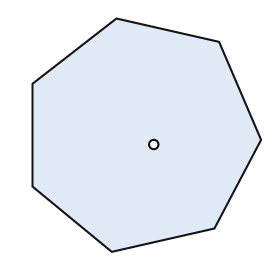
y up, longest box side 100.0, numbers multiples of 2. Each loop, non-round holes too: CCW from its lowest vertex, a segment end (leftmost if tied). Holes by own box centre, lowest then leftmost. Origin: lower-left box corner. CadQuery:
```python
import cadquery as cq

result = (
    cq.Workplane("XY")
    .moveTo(34.0, 0.0)
    .lineTo(78.0, 10.0)
    .lineTo(98.0, 48.0)
    .lineTo(80.0, 90.0)
    .lineTo(36.0, 100.0)
    .lineTo(0.0, 72.0)
    .lineTo(0.0, 28.0)
    .close()
    .moveTo(52.0, 46.0)
    .circle(2.0)
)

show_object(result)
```